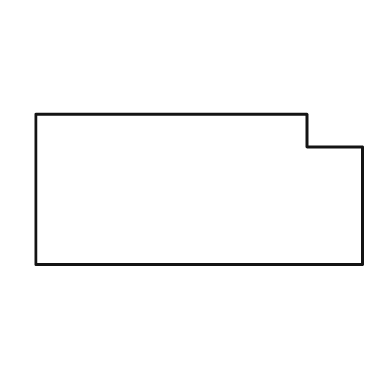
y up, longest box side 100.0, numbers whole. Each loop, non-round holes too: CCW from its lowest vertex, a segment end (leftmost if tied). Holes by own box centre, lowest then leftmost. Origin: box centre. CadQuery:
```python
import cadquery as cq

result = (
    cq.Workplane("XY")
    .moveTo(-50.0, -23.0)
    .lineTo(50.0, -23.0)
    .lineTo(50.0, 13.0)
    .lineTo(33.0, 13.0)
    .lineTo(33.0, 23.0)
    .lineTo(-50.0, 23.0)
    .close()
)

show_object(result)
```